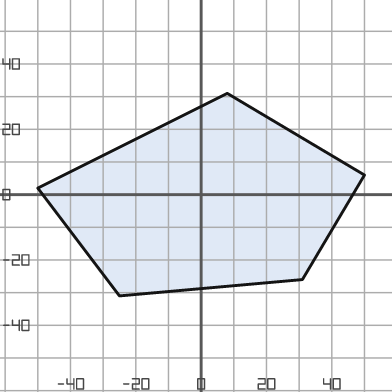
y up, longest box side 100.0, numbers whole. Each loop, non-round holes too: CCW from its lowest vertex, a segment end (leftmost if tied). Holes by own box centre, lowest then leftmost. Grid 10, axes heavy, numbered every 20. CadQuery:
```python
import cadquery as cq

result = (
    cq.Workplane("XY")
    .moveTo(-25.0, -31.0)
    .lineTo(31.0, -26.0)
    .lineTo(50.0, 6.0)
    .lineTo(8.0, 31.0)
    .lineTo(-50.0, 2.0)
    .close()
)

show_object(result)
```